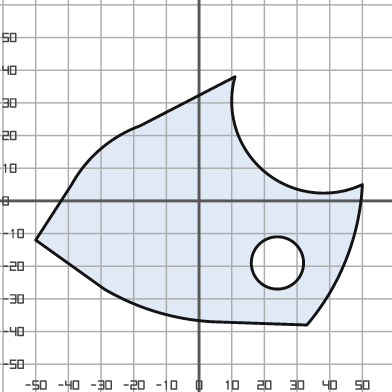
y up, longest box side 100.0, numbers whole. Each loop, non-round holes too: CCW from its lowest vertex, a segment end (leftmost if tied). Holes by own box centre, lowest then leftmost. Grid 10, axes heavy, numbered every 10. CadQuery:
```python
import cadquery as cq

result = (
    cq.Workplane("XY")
    .moveTo(33.0, -38.0)
    .threePointArc((45.0, -18.0), (50.0, 5.0))
    .threePointArc((20.0, 9.0), (11.0, 38.0))
    .lineTo(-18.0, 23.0)
    .threePointArc((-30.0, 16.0), (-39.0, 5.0))
    .lineTo(-50.0, -12.0)
    .lineTo(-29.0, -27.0)
    .threePointArc((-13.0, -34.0), (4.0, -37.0))
    .close()
    .moveTo(24.0, -19.0)
    .circle(8.0)
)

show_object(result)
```